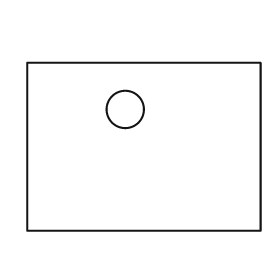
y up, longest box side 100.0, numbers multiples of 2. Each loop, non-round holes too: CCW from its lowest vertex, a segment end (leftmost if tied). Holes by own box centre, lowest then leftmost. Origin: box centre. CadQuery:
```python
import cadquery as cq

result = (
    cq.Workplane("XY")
    .moveTo(-50.0, -36.0)
    .lineTo(50.0, -36.0)
    .lineTo(50.0, 36.0)
    .lineTo(-50.0, 36.0)
    .close()
    .moveTo(-8.0, 16.0)
    .circle(8.0)
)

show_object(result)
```